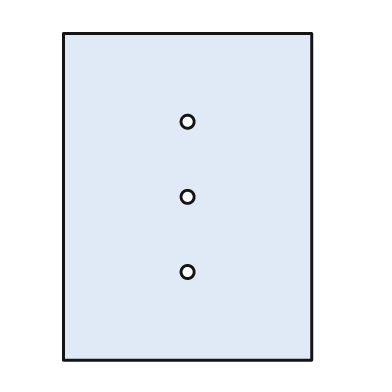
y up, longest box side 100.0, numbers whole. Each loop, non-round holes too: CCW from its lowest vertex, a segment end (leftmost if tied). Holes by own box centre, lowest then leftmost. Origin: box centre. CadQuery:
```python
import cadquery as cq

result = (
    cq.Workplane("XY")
    .moveTo(-38.0, -50.0)
    .lineTo(38.0, -50.0)
    .lineTo(38.0, 50.0)
    .lineTo(-38.0, 50.0)
    .close()
    .moveTo(0.0, -23.0)
    .circle(2.0)
    .moveTo(0.0, 0.0)
    .circle(2.0)
    .moveTo(0.0, 23.0)
    .circle(2.0)
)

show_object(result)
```